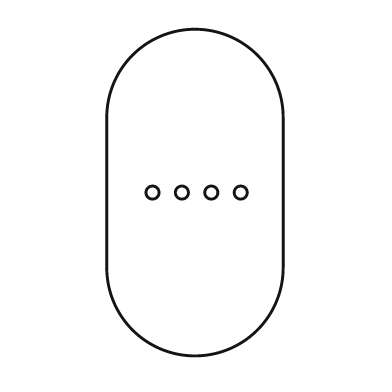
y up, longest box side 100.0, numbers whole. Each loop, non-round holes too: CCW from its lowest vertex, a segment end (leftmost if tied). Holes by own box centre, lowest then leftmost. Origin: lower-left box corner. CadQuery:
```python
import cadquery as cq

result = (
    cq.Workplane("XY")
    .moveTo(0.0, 27.0)
    .threePointArc((27.0, 0.0), (54.0, 27.0))
    .lineTo(54.0, 73.0)
    .threePointArc((27.0, 100.0), (0.0, 73.0))
    .close()
    .moveTo(14.0, 50.0)
    .circle(2.0)
    .moveTo(23.0, 50.0)
    .circle(2.0)
    .moveTo(32.0, 50.0)
    .circle(2.0)
    .moveTo(41.0, 50.0)
    .circle(2.0)
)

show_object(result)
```